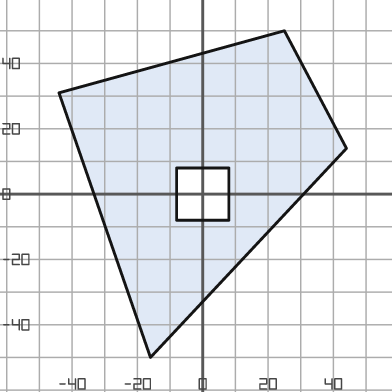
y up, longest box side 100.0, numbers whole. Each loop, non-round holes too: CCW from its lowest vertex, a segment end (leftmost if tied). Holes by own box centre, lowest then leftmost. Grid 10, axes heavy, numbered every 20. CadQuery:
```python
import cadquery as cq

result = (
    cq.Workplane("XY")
    .moveTo(-16.0, -50.0)
    .lineTo(44.0, 14.0)
    .lineTo(25.0, 50.0)
    .lineTo(-44.0, 31.0)
    .close()
    .moveTo(-8.0, -8.0)
    .lineTo(8.0, -8.0)
    .lineTo(8.0, 8.0)
    .lineTo(-8.0, 8.0)
    .close()
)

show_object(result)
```